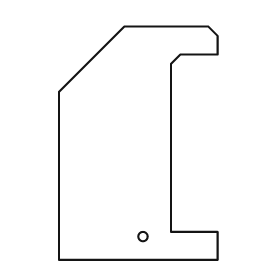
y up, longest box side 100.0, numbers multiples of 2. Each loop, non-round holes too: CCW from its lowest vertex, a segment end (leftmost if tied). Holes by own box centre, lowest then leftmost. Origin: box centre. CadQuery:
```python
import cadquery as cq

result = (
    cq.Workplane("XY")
    .moveTo(-34.0, -50.0)
    .lineTo(34.0, -50.0)
    .lineTo(34.0, -38.0)
    .lineTo(14.0, -38.0)
    .lineTo(14.0, 34.0)
    .lineTo(18.0, 38.0)
    .lineTo(34.0, 38.0)
    .lineTo(34.0, 46.0)
    .lineTo(30.0, 50.0)
    .lineTo(-6.0, 50.0)
    .lineTo(-34.0, 22.0)
    .close()
    .moveTo(2.0, -40.0)
    .circle(2.0)
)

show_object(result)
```